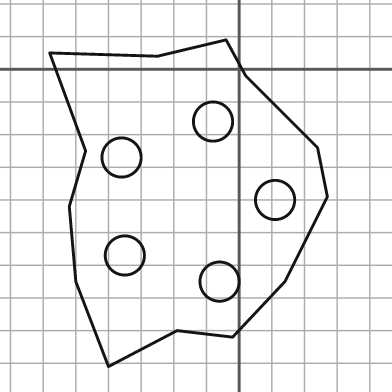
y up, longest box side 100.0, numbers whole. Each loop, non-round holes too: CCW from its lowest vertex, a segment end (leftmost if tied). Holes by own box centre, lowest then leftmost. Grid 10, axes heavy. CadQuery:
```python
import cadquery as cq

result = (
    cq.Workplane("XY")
    .moveTo(-40.0, -91.0)
    .lineTo(-19.0, -80.0)
    .lineTo(-2.0, -82.0)
    .lineTo(14.0, -65.0)
    .lineTo(27.0, -39.0)
    .lineTo(24.0, -24.0)
    .lineTo(2.0, -2.0)
    .lineTo(-4.0, 9.0)
    .lineTo(-25.0, 4.0)
    .lineTo(-58.0, 5.0)
    .lineTo(-47.0, -25.0)
    .lineTo(-52.0, -42.0)
    .lineTo(-50.0, -65.0)
    .close()
    .moveTo(-6.0, -65.0)
    .circle(6.0)
    .moveTo(-35.0, -57.0)
    .circle(6.0)
    .moveTo(11.0, -40.0)
    .circle(6.0)
    .moveTo(-36.0, -27.0)
    .circle(6.0)
    .moveTo(-8.0, -16.0)
    .circle(6.0)
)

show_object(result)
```